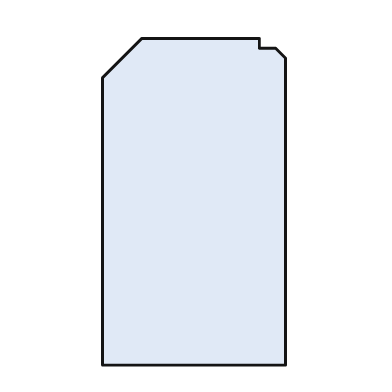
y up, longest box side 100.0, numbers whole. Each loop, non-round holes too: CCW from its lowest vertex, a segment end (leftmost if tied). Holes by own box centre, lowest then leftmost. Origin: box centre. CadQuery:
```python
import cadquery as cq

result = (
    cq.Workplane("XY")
    .moveTo(-28.0, -50.0)
    .lineTo(28.0, -50.0)
    .lineTo(28.0, 44.0)
    .lineTo(25.0, 47.0)
    .lineTo(20.0, 47.0)
    .lineTo(20.0, 50.0)
    .lineTo(-16.0, 50.0)
    .lineTo(-28.0, 38.0)
    .close()
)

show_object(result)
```